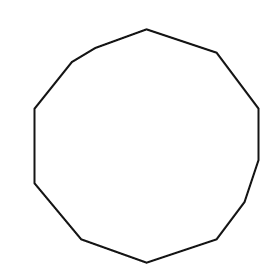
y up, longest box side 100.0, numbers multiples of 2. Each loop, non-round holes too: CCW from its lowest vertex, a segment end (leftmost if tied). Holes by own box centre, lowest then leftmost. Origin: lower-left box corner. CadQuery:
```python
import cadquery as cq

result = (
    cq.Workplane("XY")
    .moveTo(48.0, 0.0)
    .lineTo(78.0, 10.0)
    .lineTo(90.0, 26.0)
    .lineTo(96.0, 44.0)
    .lineTo(96.0, 66.0)
    .lineTo(78.0, 90.0)
    .lineTo(48.0, 100.0)
    .lineTo(26.0, 92.0)
    .lineTo(16.0, 86.0)
    .lineTo(0.0, 66.0)
    .lineTo(0.0, 34.0)
    .lineTo(20.0, 10.0)
    .close()
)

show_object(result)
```